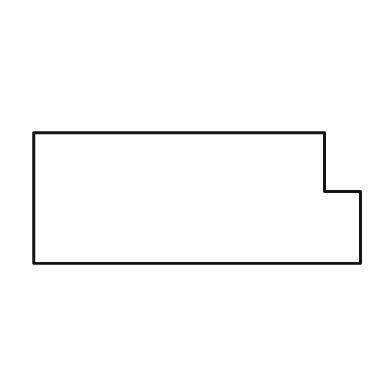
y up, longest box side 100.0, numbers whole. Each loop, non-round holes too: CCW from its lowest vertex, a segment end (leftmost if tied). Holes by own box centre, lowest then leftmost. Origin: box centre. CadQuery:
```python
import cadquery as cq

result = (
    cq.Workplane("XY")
    .moveTo(-50.0, -20.0)
    .lineTo(50.0, -20.0)
    .lineTo(50.0, 2.0)
    .lineTo(39.0, 2.0)
    .lineTo(39.0, 20.0)
    .lineTo(-50.0, 20.0)
    .close()
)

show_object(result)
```